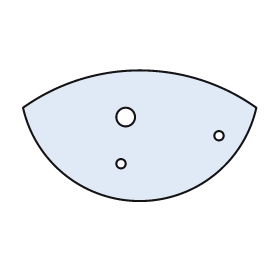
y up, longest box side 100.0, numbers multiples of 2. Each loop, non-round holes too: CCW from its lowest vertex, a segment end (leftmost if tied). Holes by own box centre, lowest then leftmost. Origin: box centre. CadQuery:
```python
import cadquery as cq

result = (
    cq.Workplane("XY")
    .moveTo(-50.0, 12.0)
    .threePointArc((0.0, -28.0), (50.0, 12.0))
    .threePointArc((0.0, 28.0), (-50.0, 12.0))
    .close()
    .moveTo(-8.0, -12.0)
    .circle(2.0)
    .moveTo(34.0, 0.0)
    .circle(2.0)
    .moveTo(-6.0, 8.0)
    .circle(4.0)
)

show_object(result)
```